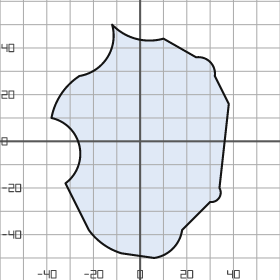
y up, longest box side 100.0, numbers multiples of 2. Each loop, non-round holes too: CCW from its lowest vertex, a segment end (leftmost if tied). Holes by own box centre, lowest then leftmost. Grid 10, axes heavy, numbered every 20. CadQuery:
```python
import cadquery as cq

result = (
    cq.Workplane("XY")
    .moveTo(6.0, -50.0)
    .threePointArc((14.0, -46.0), (18.0, -38.0))
    .lineTo(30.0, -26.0)
    .threePointArc((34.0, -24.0), (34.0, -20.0))
    .lineTo(38.0, 16.0)
    .lineTo(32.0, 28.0)
    .threePointArc((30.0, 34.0), (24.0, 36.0))
    .lineTo(10.0, 44.0)
    .threePointArc((-2.0, 44.0), (-12.0, 50.0))
    .threePointArc((-14.0, 36.0), (-26.0, 28.0))
    .threePointArc((-34.0, 20.0), (-38.0, 10.0))
    .threePointArc((-26.0, -2.0), (-32.0, -18.0))
    .lineTo(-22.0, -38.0)
    .threePointArc((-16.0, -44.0), (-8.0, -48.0))
    .close()
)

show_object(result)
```